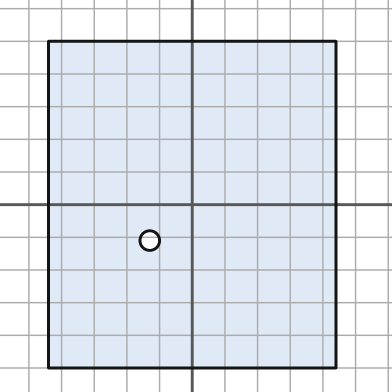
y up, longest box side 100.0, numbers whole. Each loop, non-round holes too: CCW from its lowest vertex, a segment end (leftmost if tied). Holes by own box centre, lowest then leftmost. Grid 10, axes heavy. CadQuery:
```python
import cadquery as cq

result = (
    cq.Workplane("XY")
    .moveTo(-44.0, -50.0)
    .lineTo(44.0, -50.0)
    .lineTo(44.0, 50.0)
    .lineTo(-44.0, 50.0)
    .close()
    .moveTo(-13.0, -11.0)
    .circle(3.0)
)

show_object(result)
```